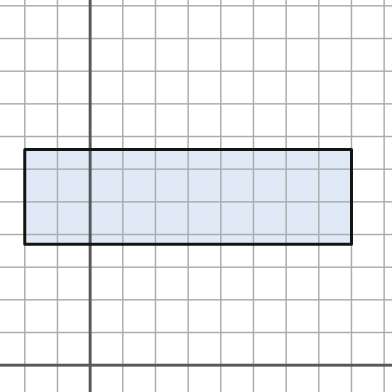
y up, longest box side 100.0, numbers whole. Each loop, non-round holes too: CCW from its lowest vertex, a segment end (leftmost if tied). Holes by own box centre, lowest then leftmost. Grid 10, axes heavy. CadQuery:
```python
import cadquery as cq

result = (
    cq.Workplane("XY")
    .moveTo(-20.0, 37.0)
    .lineTo(80.0, 37.0)
    .lineTo(80.0, 66.0)
    .lineTo(-20.0, 66.0)
    .close()
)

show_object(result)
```